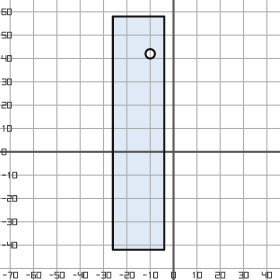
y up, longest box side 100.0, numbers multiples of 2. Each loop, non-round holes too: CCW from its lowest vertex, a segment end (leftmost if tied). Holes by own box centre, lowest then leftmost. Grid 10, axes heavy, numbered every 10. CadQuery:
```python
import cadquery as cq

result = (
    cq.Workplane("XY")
    .moveTo(-26.0, -42.0)
    .lineTo(-4.0, -42.0)
    .lineTo(-4.0, 58.0)
    .lineTo(-26.0, 58.0)
    .close()
    .moveTo(-10.0, 42.0)
    .circle(2.0)
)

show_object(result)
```